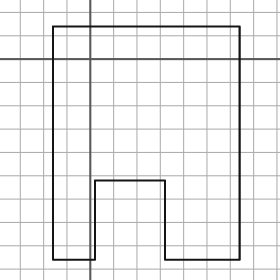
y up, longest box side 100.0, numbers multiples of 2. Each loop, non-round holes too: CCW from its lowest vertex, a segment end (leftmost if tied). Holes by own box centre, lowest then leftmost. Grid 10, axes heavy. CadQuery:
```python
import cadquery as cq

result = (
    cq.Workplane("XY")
    .moveTo(-16.0, -86.0)
    .lineTo(2.0, -86.0)
    .lineTo(2.0, -52.0)
    .lineTo(32.0, -52.0)
    .lineTo(32.0, -86.0)
    .lineTo(64.0, -86.0)
    .lineTo(64.0, 14.0)
    .lineTo(-16.0, 14.0)
    .close()
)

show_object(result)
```